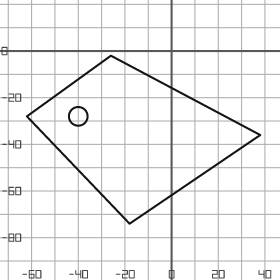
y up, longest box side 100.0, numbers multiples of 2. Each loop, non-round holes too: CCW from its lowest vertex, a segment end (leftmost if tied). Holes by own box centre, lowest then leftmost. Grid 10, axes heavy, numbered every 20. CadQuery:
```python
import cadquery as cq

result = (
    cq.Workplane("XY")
    .moveTo(-18.0, -74.0)
    .lineTo(38.0, -36.0)
    .lineTo(-26.0, -2.0)
    .lineTo(-62.0, -28.0)
    .close()
    .moveTo(-40.0, -28.0)
    .circle(4.0)
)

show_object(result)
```